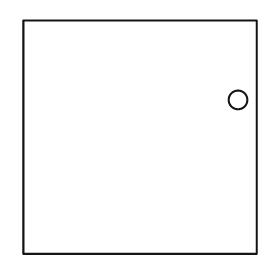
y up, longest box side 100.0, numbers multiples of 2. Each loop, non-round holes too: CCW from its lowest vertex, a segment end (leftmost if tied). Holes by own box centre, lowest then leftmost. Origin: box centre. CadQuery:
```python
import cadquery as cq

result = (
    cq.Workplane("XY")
    .moveTo(-50.0, -50.0)
    .lineTo(50.0, -50.0)
    .lineTo(50.0, 50.0)
    .lineTo(-50.0, 50.0)
    .close()
    .moveTo(42.0, 16.0)
    .circle(4.0)
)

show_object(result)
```